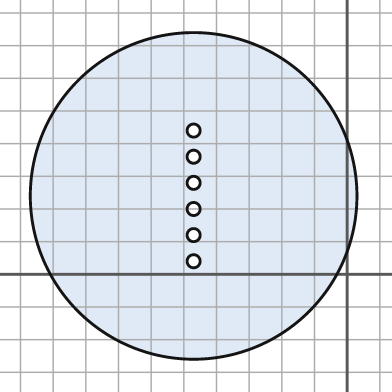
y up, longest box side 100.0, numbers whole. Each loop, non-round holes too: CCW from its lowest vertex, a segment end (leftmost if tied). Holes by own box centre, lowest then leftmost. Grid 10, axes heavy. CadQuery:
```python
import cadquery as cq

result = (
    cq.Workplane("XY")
    .moveTo(-47.0, 24.0)
    .circle(50.0)
    .moveTo(-47.0, 4.0)
    .circle(2.0)
    .moveTo(-47.0, 12.0)
    .circle(2.0)
    .moveTo(-47.0, 20.0)
    .circle(2.0)
    .moveTo(-47.0, 28.0)
    .circle(2.0)
    .moveTo(-47.0, 36.0)
    .circle(2.0)
    .moveTo(-47.0, 44.0)
    .circle(2.0)
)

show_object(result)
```